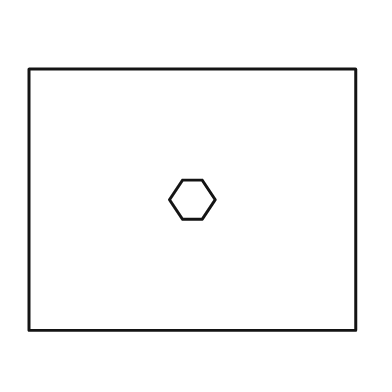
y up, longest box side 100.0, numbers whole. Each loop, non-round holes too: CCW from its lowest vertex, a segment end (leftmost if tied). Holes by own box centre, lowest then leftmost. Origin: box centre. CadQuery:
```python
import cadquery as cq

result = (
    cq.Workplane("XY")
    .moveTo(-50.0, -40.0)
    .lineTo(50.0, -40.0)
    .lineTo(50.0, 40.0)
    .lineTo(-50.0, 40.0)
    .close()
    .moveTo(-3.0, -6.0)
    .lineTo(3.0, -6.0)
    .lineTo(7.0, 0.0)
    .lineTo(3.0, 6.0)
    .lineTo(-3.0, 6.0)
    .lineTo(-7.0, 0.0)
    .close()
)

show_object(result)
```